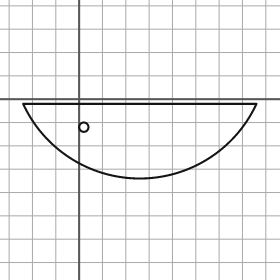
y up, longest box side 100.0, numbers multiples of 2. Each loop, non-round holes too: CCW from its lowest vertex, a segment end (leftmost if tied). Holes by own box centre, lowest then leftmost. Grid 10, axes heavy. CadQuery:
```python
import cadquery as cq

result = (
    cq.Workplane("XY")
    .moveTo(-24.0, -2.0)
    .threePointArc((26.0, -34.0), (76.0, -2.0))
    .close()
    .moveTo(2.0, -12.0)
    .circle(2.0)
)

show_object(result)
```